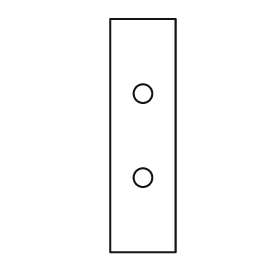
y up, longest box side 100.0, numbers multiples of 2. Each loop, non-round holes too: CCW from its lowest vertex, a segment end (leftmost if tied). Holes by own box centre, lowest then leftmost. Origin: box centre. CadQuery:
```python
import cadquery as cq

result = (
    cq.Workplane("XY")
    .moveTo(-14.0, -50.0)
    .lineTo(14.0, -50.0)
    .lineTo(14.0, 50.0)
    .lineTo(-14.0, 50.0)
    .close()
    .moveTo(0.0, -18.0)
    .circle(4.0)
    .moveTo(0.0, 18.0)
    .circle(4.0)
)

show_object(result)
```